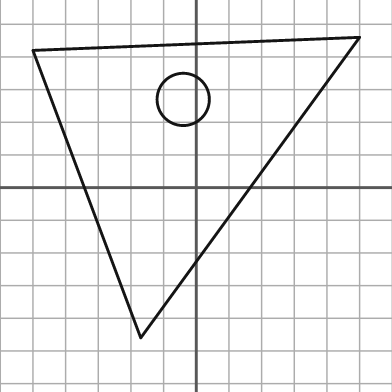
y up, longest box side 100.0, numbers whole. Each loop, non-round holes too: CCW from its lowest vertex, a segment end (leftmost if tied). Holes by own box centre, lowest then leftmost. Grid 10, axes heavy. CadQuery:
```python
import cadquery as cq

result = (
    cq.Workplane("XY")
    .moveTo(-17.0, -46.0)
    .lineTo(50.0, 46.0)
    .lineTo(-50.0, 42.0)
    .close()
    .moveTo(-4.0, 27.0)
    .circle(8.0)
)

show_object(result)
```